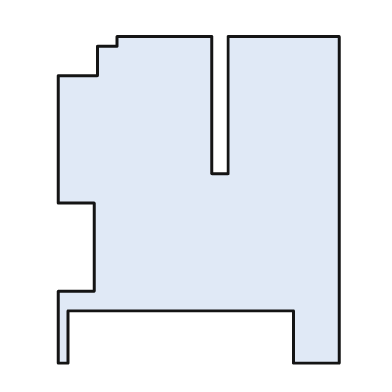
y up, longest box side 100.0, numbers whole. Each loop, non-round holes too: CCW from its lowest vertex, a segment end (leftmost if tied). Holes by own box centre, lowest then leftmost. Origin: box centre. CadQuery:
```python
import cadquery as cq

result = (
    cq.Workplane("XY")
    .moveTo(-43.0, -50.0)
    .lineTo(-40.0, -50.0)
    .lineTo(-40.0, -34.0)
    .lineTo(29.0, -34.0)
    .lineTo(29.0, -50.0)
    .lineTo(43.0, -50.0)
    .lineTo(43.0, 50.0)
    .lineTo(9.0, 50.0)
    .lineTo(9.0, 8.0)
    .lineTo(4.0, 8.0)
    .lineTo(4.0, 50.0)
    .lineTo(-25.0, 50.0)
    .lineTo(-25.0, 47.0)
    .lineTo(-31.0, 47.0)
    .lineTo(-31.0, 38.0)
    .lineTo(-43.0, 38.0)
    .lineTo(-43.0, -1.0)
    .lineTo(-32.0, -1.0)
    .lineTo(-32.0, -28.0)
    .lineTo(-43.0, -28.0)
    .close()
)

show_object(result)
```